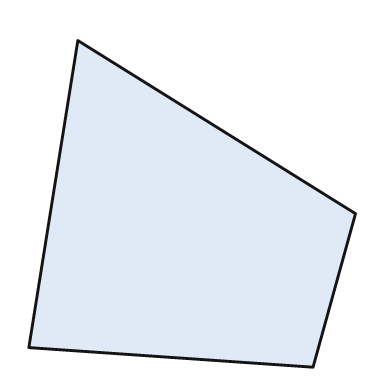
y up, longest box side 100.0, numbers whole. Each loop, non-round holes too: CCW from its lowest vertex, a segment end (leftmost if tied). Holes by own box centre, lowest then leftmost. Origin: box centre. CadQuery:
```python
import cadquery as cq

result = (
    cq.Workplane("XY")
    .moveTo(37.0, -50.0)
    .lineTo(50.0, -3.0)
    .lineTo(-35.0, 50.0)
    .lineTo(-50.0, -44.0)
    .close()
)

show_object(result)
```